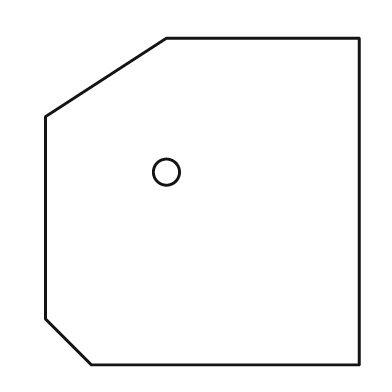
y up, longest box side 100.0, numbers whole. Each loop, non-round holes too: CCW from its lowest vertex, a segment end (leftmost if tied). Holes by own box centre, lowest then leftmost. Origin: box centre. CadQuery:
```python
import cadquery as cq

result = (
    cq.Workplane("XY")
    .moveTo(-34.0, -50.0)
    .lineTo(48.0, -50.0)
    .lineTo(48.0, 50.0)
    .lineTo(-11.0, 50.0)
    .lineTo(-48.0, 26.0)
    .lineTo(-48.0, -36.0)
    .close()
    .moveTo(-11.0, 9.0)
    .circle(4.0)
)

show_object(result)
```